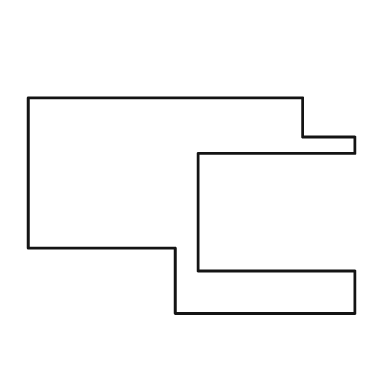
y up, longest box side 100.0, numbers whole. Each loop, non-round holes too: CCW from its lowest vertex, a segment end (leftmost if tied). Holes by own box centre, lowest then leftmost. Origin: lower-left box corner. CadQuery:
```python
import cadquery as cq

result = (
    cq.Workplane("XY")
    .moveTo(45.0, 0.0)
    .lineTo(100.0, 0.0)
    .lineTo(100.0, 13.0)
    .lineTo(52.0, 13.0)
    .lineTo(52.0, 49.0)
    .lineTo(100.0, 49.0)
    .lineTo(100.0, 54.0)
    .lineTo(84.0, 54.0)
    .lineTo(84.0, 66.0)
    .lineTo(0.0, 66.0)
    .lineTo(0.0, 20.0)
    .lineTo(45.0, 20.0)
    .close()
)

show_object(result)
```